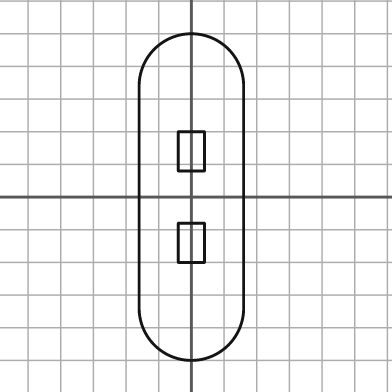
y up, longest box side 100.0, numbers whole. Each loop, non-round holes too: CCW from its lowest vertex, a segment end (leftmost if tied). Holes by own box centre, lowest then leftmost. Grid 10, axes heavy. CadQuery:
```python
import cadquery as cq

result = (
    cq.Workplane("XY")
    .moveTo(-16.0, -34.0)
    .threePointArc((0.0, -50.0), (16.0, -34.0))
    .lineTo(16.0, 34.0)
    .threePointArc((0.0, 50.0), (-16.0, 34.0))
    .close()
    .moveTo(-4.0, -20.0)
    .lineTo(4.0, -20.0)
    .lineTo(4.0, -8.0)
    .lineTo(-4.0, -8.0)
    .close()
    .moveTo(-4.0, 8.0)
    .lineTo(4.0, 8.0)
    .lineTo(4.0, 20.0)
    .lineTo(-4.0, 20.0)
    .close()
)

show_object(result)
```